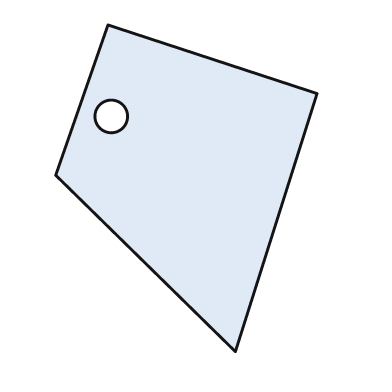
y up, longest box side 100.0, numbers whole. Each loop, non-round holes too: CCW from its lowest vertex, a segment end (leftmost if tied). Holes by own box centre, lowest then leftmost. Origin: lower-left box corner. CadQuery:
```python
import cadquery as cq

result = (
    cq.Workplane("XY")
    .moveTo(55.0, 0.0)
    .lineTo(80.0, 79.0)
    .lineTo(16.0, 100.0)
    .lineTo(0.0, 54.0)
    .close()
    .moveTo(17.0, 72.0)
    .circle(5.0)
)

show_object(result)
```